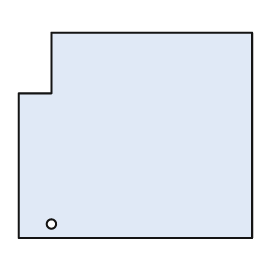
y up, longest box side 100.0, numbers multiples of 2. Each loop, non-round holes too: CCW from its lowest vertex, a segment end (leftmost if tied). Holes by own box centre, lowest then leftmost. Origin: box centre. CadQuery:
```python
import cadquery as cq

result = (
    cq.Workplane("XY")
    .moveTo(-50.0, -44.0)
    .lineTo(50.0, -44.0)
    .lineTo(50.0, 44.0)
    .lineTo(-36.0, 44.0)
    .lineTo(-36.0, 18.0)
    .lineTo(-50.0, 18.0)
    .close()
    .moveTo(-36.0, -38.0)
    .circle(2.0)
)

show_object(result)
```